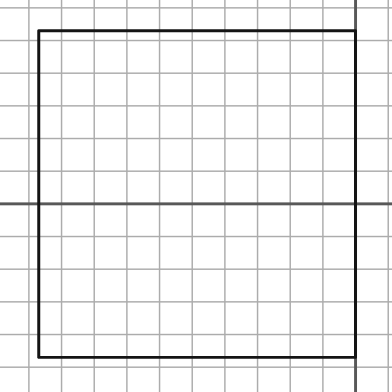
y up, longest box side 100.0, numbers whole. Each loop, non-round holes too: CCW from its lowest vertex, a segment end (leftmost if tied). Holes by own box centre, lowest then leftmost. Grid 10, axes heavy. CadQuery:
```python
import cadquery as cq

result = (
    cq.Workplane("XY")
    .moveTo(-97.0, -47.0)
    .lineTo(0.0, -47.0)
    .lineTo(0.0, 53.0)
    .lineTo(-97.0, 53.0)
    .close()
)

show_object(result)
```